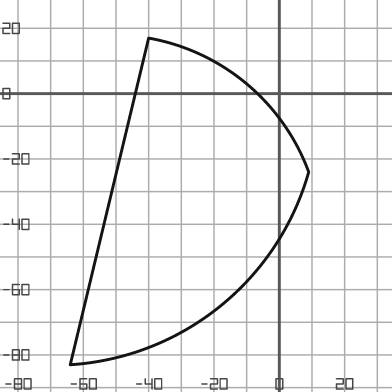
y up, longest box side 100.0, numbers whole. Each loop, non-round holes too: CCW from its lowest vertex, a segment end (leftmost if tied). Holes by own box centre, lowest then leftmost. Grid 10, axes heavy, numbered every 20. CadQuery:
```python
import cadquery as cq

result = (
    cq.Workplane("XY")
    .moveTo(-64.0, -83.0)
    .threePointArc((-18.0, -65.0), (9.0, -24.0))
    .threePointArc((-10.0, 3.0), (-40.0, 17.0))
    .close()
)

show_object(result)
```